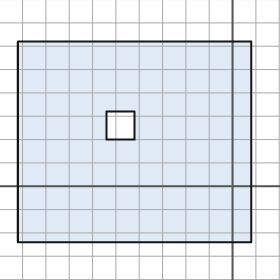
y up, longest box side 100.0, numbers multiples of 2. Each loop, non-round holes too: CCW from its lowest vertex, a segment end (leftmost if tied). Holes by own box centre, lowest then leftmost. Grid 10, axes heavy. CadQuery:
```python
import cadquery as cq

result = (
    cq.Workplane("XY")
    .moveTo(-92.0, -24.0)
    .lineTo(8.0, -24.0)
    .lineTo(8.0, 62.0)
    .lineTo(-92.0, 62.0)
    .close()
    .moveTo(-54.0, 20.0)
    .lineTo(-42.0, 20.0)
    .lineTo(-42.0, 32.0)
    .lineTo(-54.0, 32.0)
    .close()
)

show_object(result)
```